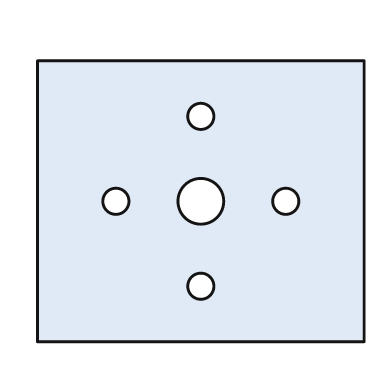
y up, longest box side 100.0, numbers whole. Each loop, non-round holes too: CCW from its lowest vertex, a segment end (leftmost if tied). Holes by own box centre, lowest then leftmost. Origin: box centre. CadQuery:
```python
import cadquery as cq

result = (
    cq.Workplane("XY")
    .moveTo(-50.0, -43.0)
    .lineTo(50.0, -43.0)
    .lineTo(50.0, 43.0)
    .lineTo(-50.0, 43.0)
    .close()
    .moveTo(0.0, -26.0)
    .circle(4.0)
    .moveTo(-26.0, 0.0)
    .circle(4.0)
    .moveTo(0.0, 0.0)
    .circle(7.0)
    .moveTo(26.0, 0.0)
    .circle(4.0)
    .moveTo(0.0, 26.0)
    .circle(4.0)
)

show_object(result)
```